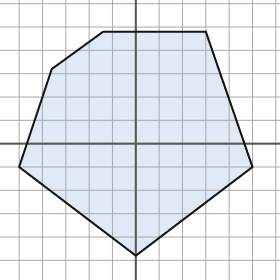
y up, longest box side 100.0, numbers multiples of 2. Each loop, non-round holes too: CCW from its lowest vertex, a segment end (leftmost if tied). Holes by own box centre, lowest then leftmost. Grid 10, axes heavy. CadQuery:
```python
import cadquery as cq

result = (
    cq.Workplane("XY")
    .moveTo(0.0, -48.0)
    .lineTo(50.0, -10.0)
    .lineTo(30.0, 48.0)
    .lineTo(-14.0, 48.0)
    .lineTo(-36.0, 32.0)
    .lineTo(-50.0, -10.0)
    .close()
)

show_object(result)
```